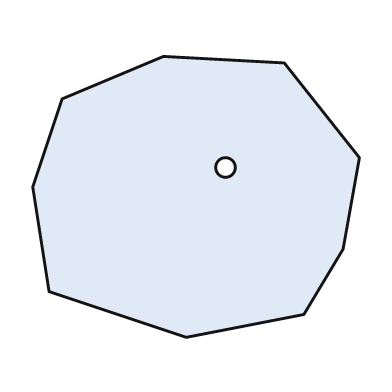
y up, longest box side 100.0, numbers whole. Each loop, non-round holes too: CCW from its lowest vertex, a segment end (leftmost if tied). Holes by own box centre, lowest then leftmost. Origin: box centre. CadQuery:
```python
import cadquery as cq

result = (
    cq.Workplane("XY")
    .moveTo(-3.0, -43.0)
    .lineTo(33.0, -36.0)
    .lineTo(45.0, -16.0)
    .lineTo(50.0, 12.0)
    .lineTo(27.0, 41.0)
    .lineTo(-10.0, 43.0)
    .lineTo(-41.0, 30.0)
    .lineTo(-50.0, 3.0)
    .lineTo(-45.0, -29.0)
    .close()
    .moveTo(9.0, 9.0)
    .circle(3.0)
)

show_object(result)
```